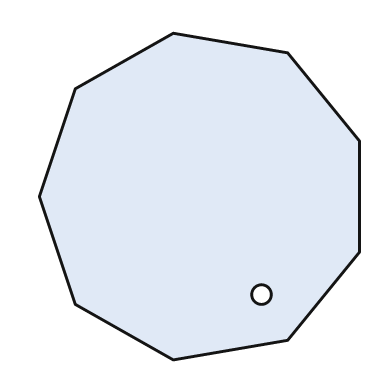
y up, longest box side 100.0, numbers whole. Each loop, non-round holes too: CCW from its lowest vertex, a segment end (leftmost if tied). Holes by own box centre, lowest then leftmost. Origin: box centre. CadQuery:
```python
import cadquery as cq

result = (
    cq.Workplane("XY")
    .moveTo(-8.0, -50.0)
    .lineTo(27.0, -44.0)
    .lineTo(49.0, -17.0)
    .lineTo(49.0, 17.0)
    .lineTo(27.0, 44.0)
    .lineTo(-8.0, 50.0)
    .lineTo(-38.0, 33.0)
    .lineTo(-49.0, 0.0)
    .lineTo(-38.0, -33.0)
    .close()
    .moveTo(19.0, -30.0)
    .circle(3.0)
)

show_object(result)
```